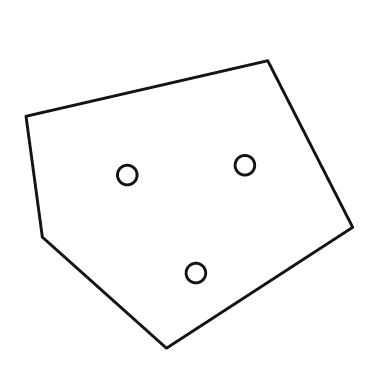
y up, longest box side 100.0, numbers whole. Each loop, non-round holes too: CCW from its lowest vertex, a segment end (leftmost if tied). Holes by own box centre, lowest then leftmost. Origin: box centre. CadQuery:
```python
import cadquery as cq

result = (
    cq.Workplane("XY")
    .moveTo(-7.0, -44.0)
    .lineTo(50.0, -7.0)
    .lineTo(24.0, 44.0)
    .lineTo(-50.0, 27.0)
    .lineTo(-45.0, -10.0)
    .close()
    .moveTo(2.0, -21.0)
    .circle(3.0)
    .moveTo(-19.0, 9.0)
    .circle(3.0)
    .moveTo(17.0, 12.0)
    .circle(3.0)
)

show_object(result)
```